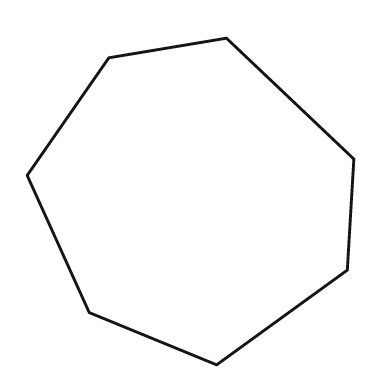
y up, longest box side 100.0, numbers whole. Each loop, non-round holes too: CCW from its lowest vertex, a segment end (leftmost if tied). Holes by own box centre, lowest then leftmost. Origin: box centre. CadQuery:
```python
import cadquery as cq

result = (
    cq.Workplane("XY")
    .moveTo(8.0, -50.0)
    .lineTo(48.0, -21.0)
    .lineTo(50.0, 13.0)
    .lineTo(11.0, 50.0)
    .lineTo(-25.0, 44.0)
    .lineTo(-50.0, 8.0)
    .lineTo(-31.0, -34.0)
    .close()
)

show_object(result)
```